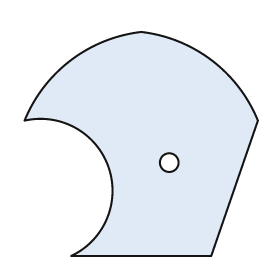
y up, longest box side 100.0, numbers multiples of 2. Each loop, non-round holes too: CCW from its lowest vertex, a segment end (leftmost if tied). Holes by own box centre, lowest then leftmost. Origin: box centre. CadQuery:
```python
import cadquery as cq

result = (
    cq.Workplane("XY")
    .moveTo(-30.0, -48.0)
    .lineTo(30.0, -48.0)
    .lineTo(50.0, 10.0)
    .threePointArc((30.0, 36.0), (0.0, 48.0))
    .threePointArc((-30.0, 36.0), (-50.0, 10.0))
    .threePointArc((-14.0, -10.0), (-30.0, -48.0))
    .close()
    .moveTo(12.0, -8.0)
    .circle(4.0)
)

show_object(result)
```